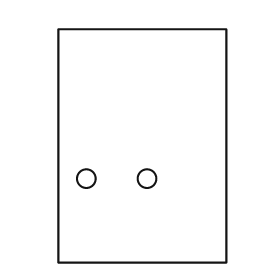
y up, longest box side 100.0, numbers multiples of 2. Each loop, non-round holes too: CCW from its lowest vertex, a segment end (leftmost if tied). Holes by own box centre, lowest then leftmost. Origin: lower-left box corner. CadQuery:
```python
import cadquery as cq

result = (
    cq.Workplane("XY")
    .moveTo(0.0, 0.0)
    .lineTo(72.0, 0.0)
    .lineTo(72.0, 100.0)
    .lineTo(0.0, 100.0)
    .close()
    .moveTo(12.0, 36.0)
    .circle(4.0)
    .moveTo(38.0, 36.0)
    .circle(4.0)
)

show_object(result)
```